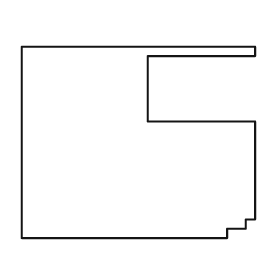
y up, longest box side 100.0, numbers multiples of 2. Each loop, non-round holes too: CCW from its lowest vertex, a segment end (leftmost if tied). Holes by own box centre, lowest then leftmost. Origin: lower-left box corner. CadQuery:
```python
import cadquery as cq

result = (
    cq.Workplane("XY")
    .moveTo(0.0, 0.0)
    .lineTo(88.0, 0.0)
    .lineTo(88.0, 4.0)
    .lineTo(96.0, 4.0)
    .lineTo(96.0, 8.0)
    .lineTo(100.0, 8.0)
    .lineTo(100.0, 50.0)
    .lineTo(54.0, 50.0)
    .lineTo(54.0, 78.0)
    .lineTo(100.0, 78.0)
    .lineTo(100.0, 82.0)
    .lineTo(0.0, 82.0)
    .close()
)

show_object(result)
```